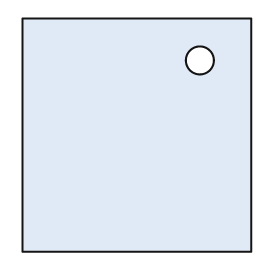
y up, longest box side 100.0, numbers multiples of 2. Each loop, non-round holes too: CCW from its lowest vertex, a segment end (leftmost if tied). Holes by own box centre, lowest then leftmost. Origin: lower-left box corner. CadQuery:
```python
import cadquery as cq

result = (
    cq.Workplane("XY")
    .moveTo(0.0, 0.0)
    .lineTo(98.0, 0.0)
    .lineTo(98.0, 100.0)
    .lineTo(0.0, 100.0)
    .close()
    .moveTo(76.0, 82.0)
    .circle(6.0)
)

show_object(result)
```